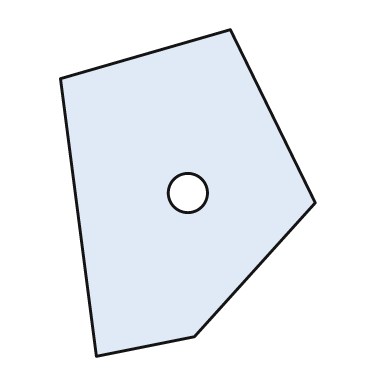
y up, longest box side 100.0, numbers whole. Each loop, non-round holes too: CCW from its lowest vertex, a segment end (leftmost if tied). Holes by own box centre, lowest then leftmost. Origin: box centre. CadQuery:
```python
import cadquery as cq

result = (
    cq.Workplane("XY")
    .moveTo(-28.0, -50.0)
    .lineTo(2.0, -44.0)
    .lineTo(39.0, -3.0)
    .lineTo(13.0, 50.0)
    .lineTo(-39.0, 35.0)
    .close()
    .moveTo(0.0, 0.0)
    .circle(6.0)
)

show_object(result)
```